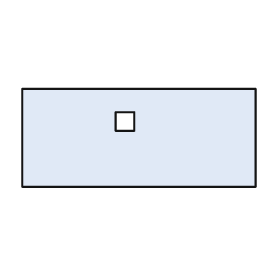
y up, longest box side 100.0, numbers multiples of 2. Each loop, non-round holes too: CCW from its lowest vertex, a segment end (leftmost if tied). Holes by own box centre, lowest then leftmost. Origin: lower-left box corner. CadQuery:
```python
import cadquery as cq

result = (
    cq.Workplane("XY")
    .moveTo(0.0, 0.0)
    .lineTo(100.0, 0.0)
    .lineTo(100.0, 42.0)
    .lineTo(0.0, 42.0)
    .close()
    .moveTo(40.0, 24.0)
    .lineTo(48.0, 24.0)
    .lineTo(48.0, 32.0)
    .lineTo(40.0, 32.0)
    .close()
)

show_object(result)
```